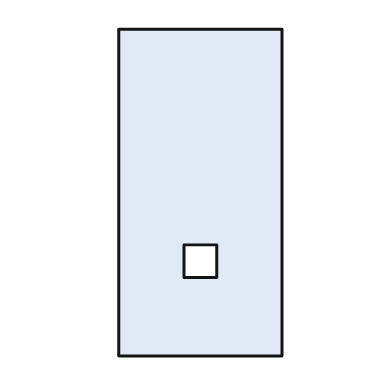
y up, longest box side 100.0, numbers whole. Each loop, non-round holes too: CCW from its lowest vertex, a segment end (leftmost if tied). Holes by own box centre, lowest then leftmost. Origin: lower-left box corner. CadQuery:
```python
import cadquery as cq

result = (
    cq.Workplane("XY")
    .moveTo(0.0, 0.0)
    .lineTo(50.0, 0.0)
    .lineTo(50.0, 100.0)
    .lineTo(0.0, 100.0)
    .close()
    .moveTo(20.0, 24.0)
    .lineTo(30.0, 24.0)
    .lineTo(30.0, 34.0)
    .lineTo(20.0, 34.0)
    .close()
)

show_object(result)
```